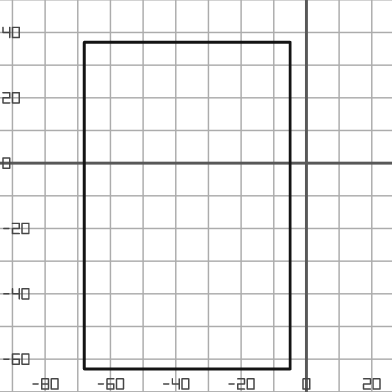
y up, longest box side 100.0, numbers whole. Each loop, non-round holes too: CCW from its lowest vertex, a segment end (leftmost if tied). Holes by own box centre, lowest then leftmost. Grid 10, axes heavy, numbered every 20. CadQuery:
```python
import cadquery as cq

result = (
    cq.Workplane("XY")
    .moveTo(-68.0, -63.0)
    .lineTo(-5.0, -63.0)
    .lineTo(-5.0, 37.0)
    .lineTo(-68.0, 37.0)
    .close()
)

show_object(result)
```